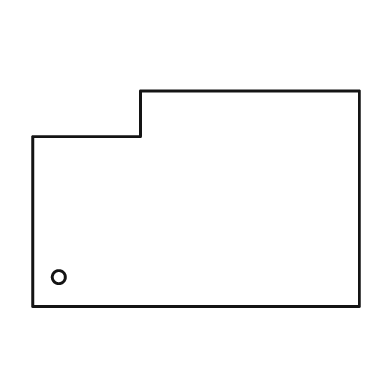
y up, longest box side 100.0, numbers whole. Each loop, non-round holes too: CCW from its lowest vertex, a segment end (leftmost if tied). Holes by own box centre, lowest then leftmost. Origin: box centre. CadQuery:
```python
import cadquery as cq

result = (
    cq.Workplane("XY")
    .moveTo(-50.0, -33.0)
    .lineTo(50.0, -33.0)
    .lineTo(50.0, 33.0)
    .lineTo(-17.0, 33.0)
    .lineTo(-17.0, 19.0)
    .lineTo(-50.0, 19.0)
    .close()
    .moveTo(-42.0, -24.0)
    .circle(2.0)
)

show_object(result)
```